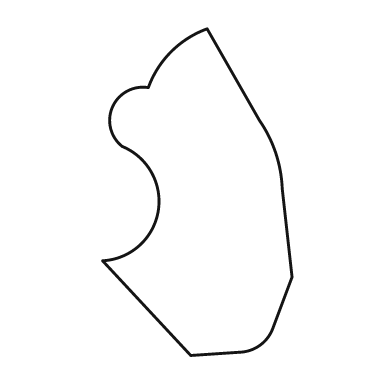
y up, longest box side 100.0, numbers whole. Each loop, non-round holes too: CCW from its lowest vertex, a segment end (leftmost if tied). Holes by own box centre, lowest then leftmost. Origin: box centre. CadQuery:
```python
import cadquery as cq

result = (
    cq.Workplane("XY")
    .moveTo(-2.0, -50.0)
    .lineTo(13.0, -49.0)
    .threePointArc((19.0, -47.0), (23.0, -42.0))
    .lineTo(29.0, -26.0)
    .lineTo(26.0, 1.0)
    .threePointArc((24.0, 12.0), (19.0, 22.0))
    .lineTo(3.0, 50.0)
    .threePointArc((-8.0, 43.0), (-15.0, 32.0))
    .threePointArc((-26.0, 26.0), (-23.0, 14.0))
    .threePointArc((-12.0, -6.0), (-29.0, -21.0))
    .close()
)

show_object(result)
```